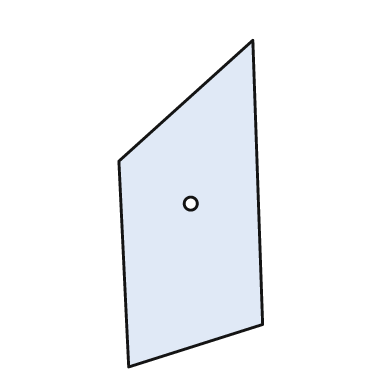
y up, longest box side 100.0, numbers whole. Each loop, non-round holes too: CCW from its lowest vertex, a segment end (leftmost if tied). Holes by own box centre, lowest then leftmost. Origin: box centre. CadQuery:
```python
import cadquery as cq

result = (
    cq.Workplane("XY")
    .moveTo(-19.0, -50.0)
    .lineTo(22.0, -37.0)
    .lineTo(19.0, 50.0)
    .lineTo(-22.0, 13.0)
    .close()
    .moveTo(0.0, 0.0)
    .circle(2.0)
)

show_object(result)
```